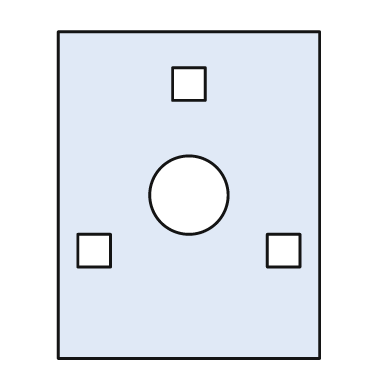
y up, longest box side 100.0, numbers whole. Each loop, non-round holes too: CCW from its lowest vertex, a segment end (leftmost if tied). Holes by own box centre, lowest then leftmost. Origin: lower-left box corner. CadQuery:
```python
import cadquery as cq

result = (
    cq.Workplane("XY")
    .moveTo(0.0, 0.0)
    .lineTo(80.0, 0.0)
    .lineTo(80.0, 100.0)
    .lineTo(0.0, 100.0)
    .close()
    .moveTo(6.0, 28.0)
    .lineTo(16.0, 28.0)
    .lineTo(16.0, 38.0)
    .lineTo(6.0, 38.0)
    .close()
    .moveTo(64.0, 28.0)
    .lineTo(74.0, 28.0)
    .lineTo(74.0, 38.0)
    .lineTo(64.0, 38.0)
    .close()
    .moveTo(40.0, 50.0)
    .circle(12.0)
    .moveTo(35.0, 79.0)
    .lineTo(45.0, 79.0)
    .lineTo(45.0, 89.0)
    .lineTo(35.0, 89.0)
    .close()
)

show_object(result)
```